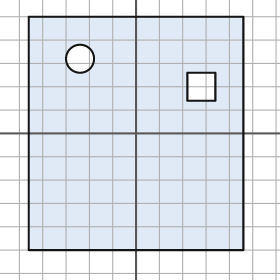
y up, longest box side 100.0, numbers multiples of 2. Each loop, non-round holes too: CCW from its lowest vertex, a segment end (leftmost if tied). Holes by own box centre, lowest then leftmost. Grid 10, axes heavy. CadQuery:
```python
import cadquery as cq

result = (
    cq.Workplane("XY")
    .moveTo(-46.0, -50.0)
    .lineTo(46.0, -50.0)
    .lineTo(46.0, 50.0)
    .lineTo(-46.0, 50.0)
    .close()
    .moveTo(22.0, 14.0)
    .lineTo(34.0, 14.0)
    .lineTo(34.0, 26.0)
    .lineTo(22.0, 26.0)
    .close()
    .moveTo(-24.0, 32.0)
    .circle(6.0)
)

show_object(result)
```